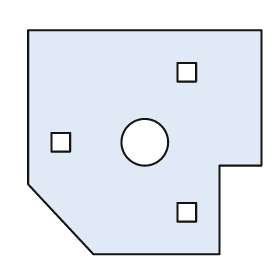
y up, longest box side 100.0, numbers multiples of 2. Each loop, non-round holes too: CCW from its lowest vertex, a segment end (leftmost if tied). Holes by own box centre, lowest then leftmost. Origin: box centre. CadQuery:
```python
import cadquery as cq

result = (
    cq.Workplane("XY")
    .moveTo(-22.0, -48.0)
    .lineTo(32.0, -48.0)
    .lineTo(32.0, -10.0)
    .lineTo(50.0, -10.0)
    .lineTo(50.0, 48.0)
    .lineTo(-50.0, 48.0)
    .lineTo(-50.0, -18.0)
    .close()
    .moveTo(14.0, -34.0)
    .lineTo(22.0, -34.0)
    .lineTo(22.0, -26.0)
    .lineTo(14.0, -26.0)
    .close()
    .moveTo(-40.0, -4.0)
    .lineTo(-32.0, -4.0)
    .lineTo(-32.0, 4.0)
    .lineTo(-40.0, 4.0)
    .close()
    .moveTo(0.0, 0.0)
    .circle(10.0)
    .moveTo(14.0, 26.0)
    .lineTo(22.0, 26.0)
    .lineTo(22.0, 34.0)
    .lineTo(14.0, 34.0)
    .close()
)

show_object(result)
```